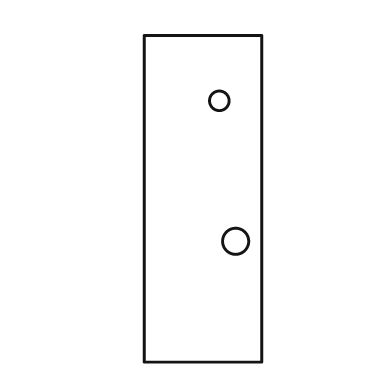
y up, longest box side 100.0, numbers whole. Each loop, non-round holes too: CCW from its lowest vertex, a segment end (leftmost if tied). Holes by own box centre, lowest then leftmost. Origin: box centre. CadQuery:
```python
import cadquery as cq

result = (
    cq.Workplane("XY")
    .moveTo(-18.0, -50.0)
    .lineTo(18.0, -50.0)
    .lineTo(18.0, 50.0)
    .lineTo(-18.0, 50.0)
    .close()
    .moveTo(10.0, -13.0)
    .circle(4.0)
    .moveTo(5.0, 30.0)
    .circle(3.0)
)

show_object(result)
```